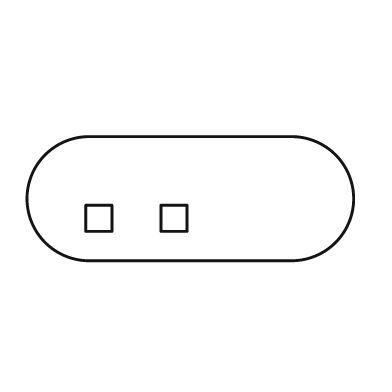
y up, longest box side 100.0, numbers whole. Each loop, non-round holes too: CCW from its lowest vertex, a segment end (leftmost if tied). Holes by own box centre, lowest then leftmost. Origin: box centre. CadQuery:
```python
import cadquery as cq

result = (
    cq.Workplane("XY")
    .moveTo(-31.0, -19.0)
    .lineTo(31.0, -19.0)
    .threePointArc((50.0, 0.0), (31.0, 19.0))
    .lineTo(-31.0, 19.0)
    .threePointArc((-50.0, 0.0), (-31.0, -19.0))
    .close()
    .moveTo(-32.0, -10.0)
    .lineTo(-24.0, -10.0)
    .lineTo(-24.0, -2.0)
    .lineTo(-32.0, -2.0)
    .close()
    .moveTo(-9.0, -10.0)
    .lineTo(-1.0, -10.0)
    .lineTo(-1.0, -2.0)
    .lineTo(-9.0, -2.0)
    .close()
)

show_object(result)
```